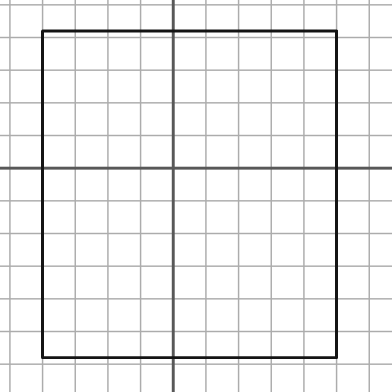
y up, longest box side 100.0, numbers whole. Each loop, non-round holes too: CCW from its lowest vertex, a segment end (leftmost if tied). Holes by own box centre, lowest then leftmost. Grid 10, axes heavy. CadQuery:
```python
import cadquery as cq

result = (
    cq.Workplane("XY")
    .moveTo(-40.0, -58.0)
    .lineTo(50.0, -58.0)
    .lineTo(50.0, 42.0)
    .lineTo(-40.0, 42.0)
    .close()
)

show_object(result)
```